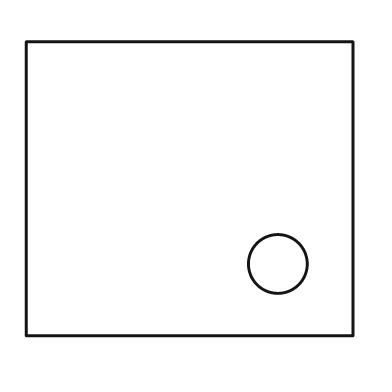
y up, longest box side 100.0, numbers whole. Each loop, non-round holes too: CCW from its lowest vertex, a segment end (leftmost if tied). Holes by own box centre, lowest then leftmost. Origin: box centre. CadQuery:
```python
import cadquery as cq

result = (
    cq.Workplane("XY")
    .moveTo(-50.0, -45.0)
    .lineTo(50.0, -45.0)
    .lineTo(50.0, 45.0)
    .lineTo(-50.0, 45.0)
    .close()
    .moveTo(27.0, -23.0)
    .circle(9.0)
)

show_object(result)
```